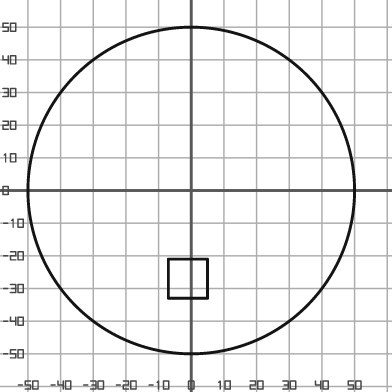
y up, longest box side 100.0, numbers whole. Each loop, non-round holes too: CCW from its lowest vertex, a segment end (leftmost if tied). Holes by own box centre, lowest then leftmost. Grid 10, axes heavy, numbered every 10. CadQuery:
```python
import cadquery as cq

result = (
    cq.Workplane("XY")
    .moveTo(0.0, 0.0)
    .circle(50.0)
    .moveTo(-7.0, -33.0)
    .lineTo(5.0, -33.0)
    .lineTo(5.0, -21.0)
    .lineTo(-7.0, -21.0)
    .close()
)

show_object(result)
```